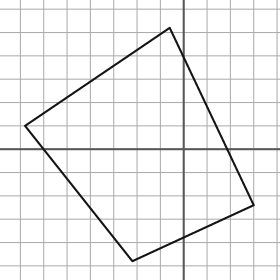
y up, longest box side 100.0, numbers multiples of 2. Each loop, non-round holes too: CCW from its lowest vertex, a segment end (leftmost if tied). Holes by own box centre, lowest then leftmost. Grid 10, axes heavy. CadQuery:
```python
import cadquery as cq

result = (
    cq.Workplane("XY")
    .moveTo(-22.0, -48.0)
    .lineTo(30.0, -24.0)
    .lineTo(-6.0, 52.0)
    .lineTo(-68.0, 10.0)
    .close()
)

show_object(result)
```